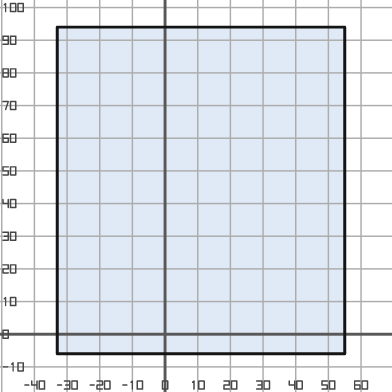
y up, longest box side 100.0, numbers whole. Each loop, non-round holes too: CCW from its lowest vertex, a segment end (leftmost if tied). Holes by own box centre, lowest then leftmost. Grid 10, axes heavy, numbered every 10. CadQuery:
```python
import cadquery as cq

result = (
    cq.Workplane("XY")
    .moveTo(-33.0, -6.0)
    .lineTo(55.0, -6.0)
    .lineTo(55.0, 94.0)
    .lineTo(-33.0, 94.0)
    .close()
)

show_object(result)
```